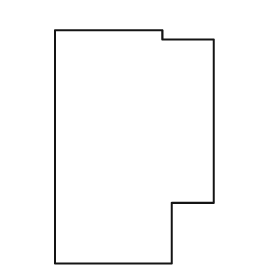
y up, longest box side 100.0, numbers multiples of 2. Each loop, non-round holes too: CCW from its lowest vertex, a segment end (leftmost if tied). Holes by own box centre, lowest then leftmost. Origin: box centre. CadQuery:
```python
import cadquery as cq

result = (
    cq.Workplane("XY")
    .moveTo(-34.0, -50.0)
    .lineTo(16.0, -50.0)
    .lineTo(16.0, -24.0)
    .lineTo(34.0, -24.0)
    .lineTo(34.0, 46.0)
    .lineTo(12.0, 46.0)
    .lineTo(12.0, 50.0)
    .lineTo(-34.0, 50.0)
    .close()
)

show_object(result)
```